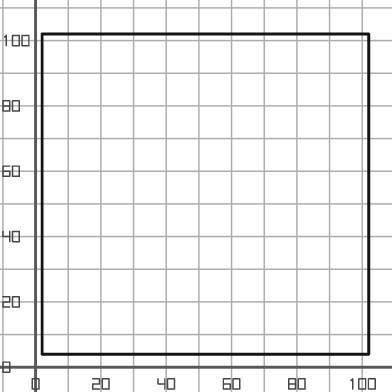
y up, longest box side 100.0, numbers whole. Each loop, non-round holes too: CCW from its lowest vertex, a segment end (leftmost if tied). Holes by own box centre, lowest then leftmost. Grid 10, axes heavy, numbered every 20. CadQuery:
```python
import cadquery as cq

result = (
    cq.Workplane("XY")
    .moveTo(2.0, 4.0)
    .lineTo(102.0, 4.0)
    .lineTo(102.0, 102.0)
    .lineTo(2.0, 102.0)
    .close()
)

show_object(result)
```